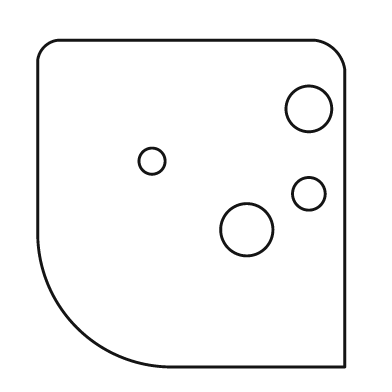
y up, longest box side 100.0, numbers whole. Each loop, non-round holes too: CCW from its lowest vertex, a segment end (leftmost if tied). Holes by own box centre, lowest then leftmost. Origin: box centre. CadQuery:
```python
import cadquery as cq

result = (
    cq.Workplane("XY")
    .moveTo(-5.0, -50.0)
    .lineTo(47.0, -50.0)
    .lineTo(47.0, 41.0)
    .threePointArc((44.0, 47.0), (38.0, 50.0))
    .lineTo(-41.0, 50.0)
    .threePointArc((-45.0, 48.0), (-47.0, 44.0))
    .lineTo(-47.0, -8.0)
    .threePointArc((-35.0, -38.0), (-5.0, -50.0))
    .close()
    .moveTo(17.0, -8.0)
    .circle(8.0)
    .moveTo(36.0, 3.0)
    .circle(5.0)
    .moveTo(-12.0, 13.0)
    .circle(4.0)
    .moveTo(36.0, 29.0)
    .circle(7.0)
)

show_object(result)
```